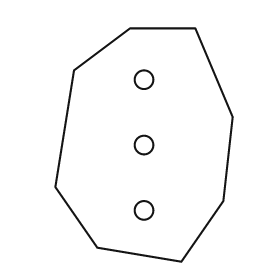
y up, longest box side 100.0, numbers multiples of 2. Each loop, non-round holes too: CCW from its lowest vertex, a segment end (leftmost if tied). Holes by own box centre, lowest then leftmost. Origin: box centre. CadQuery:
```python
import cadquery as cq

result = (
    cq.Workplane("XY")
    .moveTo(16.0, -50.0)
    .lineTo(34.0, -24.0)
    .lineTo(38.0, 12.0)
    .lineTo(22.0, 50.0)
    .lineTo(-6.0, 50.0)
    .lineTo(-30.0, 32.0)
    .lineTo(-38.0, -18.0)
    .lineTo(-20.0, -44.0)
    .close()
    .moveTo(0.0, -28.0)
    .circle(4.0)
    .moveTo(0.0, 0.0)
    .circle(4.0)
    .moveTo(0.0, 28.0)
    .circle(4.0)
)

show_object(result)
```